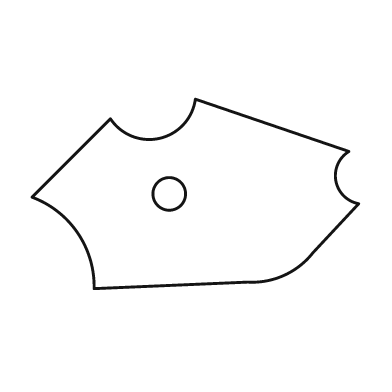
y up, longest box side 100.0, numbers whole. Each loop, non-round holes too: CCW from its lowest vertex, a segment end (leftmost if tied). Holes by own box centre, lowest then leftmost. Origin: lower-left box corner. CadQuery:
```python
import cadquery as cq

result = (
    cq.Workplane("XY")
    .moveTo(19.0, 0.0)
    .lineTo(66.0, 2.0)
    .threePointArc((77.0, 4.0), (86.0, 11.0))
    .lineTo(100.0, 26.0)
    .threePointArc((93.0, 33.0), (97.0, 42.0))
    .lineTo(50.0, 58.0)
    .threePointArc((39.0, 46.0), (24.0, 52.0))
    .lineTo(0.0, 28.0)
    .threePointArc((14.0, 17.0), (19.0, 0.0))
    .close()
    .moveTo(42.0, 29.0)
    .circle(5.0)
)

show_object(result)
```